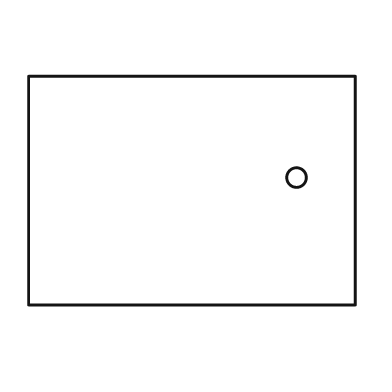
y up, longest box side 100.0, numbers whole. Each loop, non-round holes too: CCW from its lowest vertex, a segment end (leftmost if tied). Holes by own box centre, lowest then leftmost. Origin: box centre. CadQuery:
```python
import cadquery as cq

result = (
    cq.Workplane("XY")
    .moveTo(-50.0, -35.0)
    .lineTo(50.0, -35.0)
    .lineTo(50.0, 35.0)
    .lineTo(-50.0, 35.0)
    .close()
    .moveTo(32.0, 4.0)
    .circle(3.0)
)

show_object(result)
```